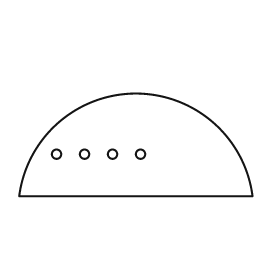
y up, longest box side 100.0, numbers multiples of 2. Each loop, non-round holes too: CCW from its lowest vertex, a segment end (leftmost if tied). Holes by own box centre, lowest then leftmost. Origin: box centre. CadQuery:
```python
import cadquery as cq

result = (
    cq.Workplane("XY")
    .moveTo(-50.0, -22.0)
    .lineTo(50.0, -22.0)
    .threePointArc((0.0, 22.0), (-50.0, -22.0))
    .close()
    .moveTo(-34.0, -4.0)
    .circle(2.0)
    .moveTo(-22.0, -4.0)
    .circle(2.0)
    .moveTo(-10.0, -4.0)
    .circle(2.0)
    .moveTo(2.0, -4.0)
    .circle(2.0)
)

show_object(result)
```